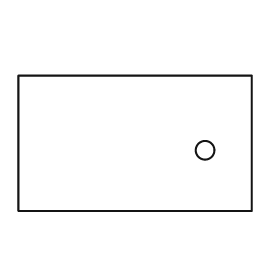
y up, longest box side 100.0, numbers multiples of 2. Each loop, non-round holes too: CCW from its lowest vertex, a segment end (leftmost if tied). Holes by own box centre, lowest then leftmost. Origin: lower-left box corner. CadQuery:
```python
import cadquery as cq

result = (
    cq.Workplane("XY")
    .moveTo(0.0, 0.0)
    .lineTo(100.0, 0.0)
    .lineTo(100.0, 58.0)
    .lineTo(0.0, 58.0)
    .close()
    .moveTo(80.0, 26.0)
    .circle(4.0)
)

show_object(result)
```